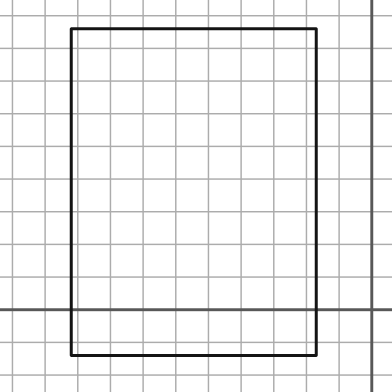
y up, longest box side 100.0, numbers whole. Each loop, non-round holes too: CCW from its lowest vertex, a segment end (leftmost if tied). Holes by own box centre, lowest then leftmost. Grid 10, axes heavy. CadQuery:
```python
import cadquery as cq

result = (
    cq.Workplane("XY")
    .moveTo(-92.0, -14.0)
    .lineTo(-17.0, -14.0)
    .lineTo(-17.0, 86.0)
    .lineTo(-92.0, 86.0)
    .close()
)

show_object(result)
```